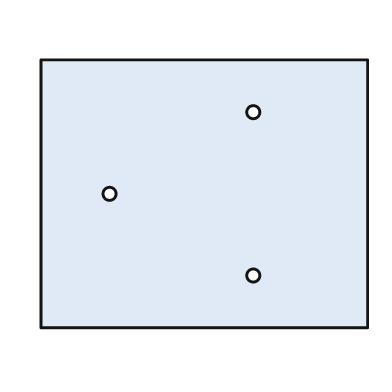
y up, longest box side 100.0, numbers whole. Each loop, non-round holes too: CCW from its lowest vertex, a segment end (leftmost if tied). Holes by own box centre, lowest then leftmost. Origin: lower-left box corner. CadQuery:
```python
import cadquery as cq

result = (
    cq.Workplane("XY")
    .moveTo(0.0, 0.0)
    .lineTo(100.0, 0.0)
    .lineTo(100.0, 82.0)
    .lineTo(0.0, 82.0)
    .close()
    .moveTo(65.0, 16.0)
    .circle(2.0)
    .moveTo(21.0, 41.0)
    .circle(2.0)
    .moveTo(65.0, 66.0)
    .circle(2.0)
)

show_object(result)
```